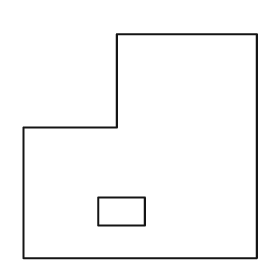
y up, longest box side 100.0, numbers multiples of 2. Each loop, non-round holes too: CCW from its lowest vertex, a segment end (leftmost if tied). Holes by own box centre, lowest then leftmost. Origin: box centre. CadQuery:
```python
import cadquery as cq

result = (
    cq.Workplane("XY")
    .moveTo(-50.0, -48.0)
    .lineTo(50.0, -48.0)
    .lineTo(50.0, 48.0)
    .lineTo(-10.0, 48.0)
    .lineTo(-10.0, 8.0)
    .lineTo(-50.0, 8.0)
    .close()
    .moveTo(-18.0, -34.0)
    .lineTo(2.0, -34.0)
    .lineTo(2.0, -22.0)
    .lineTo(-18.0, -22.0)
    .close()
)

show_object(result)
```